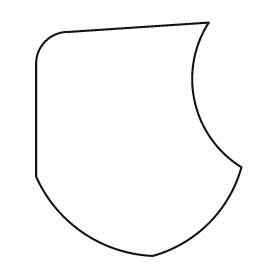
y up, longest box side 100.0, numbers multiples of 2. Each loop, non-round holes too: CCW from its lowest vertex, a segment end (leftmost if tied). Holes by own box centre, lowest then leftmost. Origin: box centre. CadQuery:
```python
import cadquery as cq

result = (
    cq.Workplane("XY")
    .moveTo(6.0, -50.0)
    .threePointArc((30.0, -36.0), (44.0, -12.0))
    .threePointArc((24.0, 16.0), (30.0, 50.0))
    .lineTo(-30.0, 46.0)
    .threePointArc((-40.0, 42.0), (-44.0, 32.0))
    .lineTo(-44.0, -16.0)
    .threePointArc((-24.0, -40.0), (6.0, -50.0))
    .close()
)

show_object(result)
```